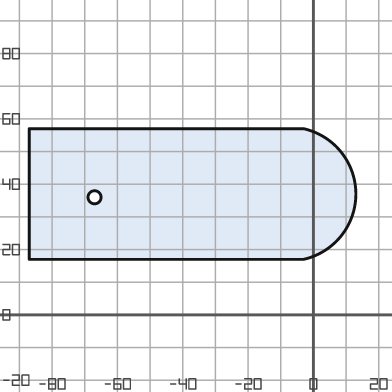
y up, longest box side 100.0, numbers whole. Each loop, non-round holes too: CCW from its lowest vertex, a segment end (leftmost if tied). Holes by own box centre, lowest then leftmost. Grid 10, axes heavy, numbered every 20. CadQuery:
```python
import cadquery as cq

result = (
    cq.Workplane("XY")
    .moveTo(-87.0, 17.0)
    .lineTo(-3.0, 17.0)
    .threePointArc((13.0, 37.0), (-3.0, 57.0))
    .lineTo(-87.0, 57.0)
    .close()
    .moveTo(-67.0, 36.0)
    .circle(2.0)
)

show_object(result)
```